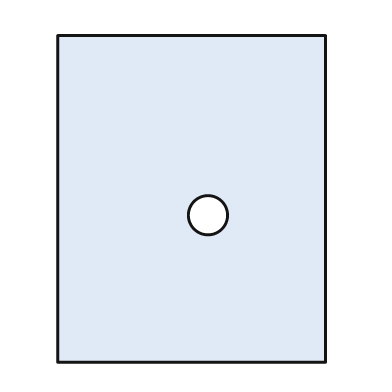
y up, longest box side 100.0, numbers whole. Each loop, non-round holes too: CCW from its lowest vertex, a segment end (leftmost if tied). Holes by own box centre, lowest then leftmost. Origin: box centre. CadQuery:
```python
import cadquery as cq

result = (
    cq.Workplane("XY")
    .moveTo(-41.0, -50.0)
    .lineTo(41.0, -50.0)
    .lineTo(41.0, 50.0)
    .lineTo(-41.0, 50.0)
    .close()
    .moveTo(5.0, -5.0)
    .circle(6.0)
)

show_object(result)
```